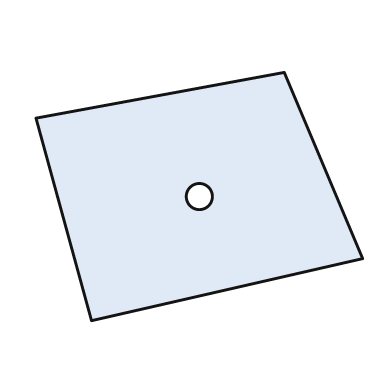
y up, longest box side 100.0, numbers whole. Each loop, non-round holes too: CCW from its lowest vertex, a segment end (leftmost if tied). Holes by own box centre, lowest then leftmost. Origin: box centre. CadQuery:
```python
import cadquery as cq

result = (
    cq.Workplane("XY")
    .moveTo(-33.0, -38.0)
    .lineTo(50.0, -19.0)
    .lineTo(26.0, 38.0)
    .lineTo(-50.0, 24.0)
    .close()
    .moveTo(0.0, 0.0)
    .circle(4.0)
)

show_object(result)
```